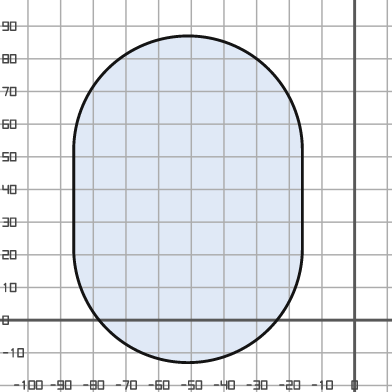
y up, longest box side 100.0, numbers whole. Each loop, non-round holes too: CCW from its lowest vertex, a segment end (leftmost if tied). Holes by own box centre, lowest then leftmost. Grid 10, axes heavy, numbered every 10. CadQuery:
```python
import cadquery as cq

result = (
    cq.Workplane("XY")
    .moveTo(-86.0, 22.0)
    .threePointArc((-51.0, -13.0), (-16.0, 22.0))
    .lineTo(-16.0, 52.0)
    .threePointArc((-51.0, 87.0), (-86.0, 52.0))
    .close()
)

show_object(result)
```